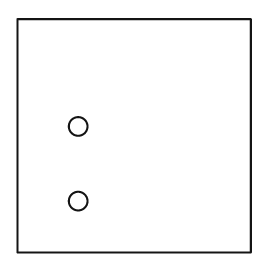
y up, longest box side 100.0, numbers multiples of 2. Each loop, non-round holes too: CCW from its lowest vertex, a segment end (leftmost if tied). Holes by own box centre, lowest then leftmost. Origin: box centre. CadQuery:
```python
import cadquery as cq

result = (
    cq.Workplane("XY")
    .moveTo(-50.0, -50.0)
    .lineTo(50.0, -50.0)
    .lineTo(50.0, 50.0)
    .lineTo(-50.0, 50.0)
    .close()
    .moveTo(-24.0, -28.0)
    .circle(4.0)
    .moveTo(-24.0, 4.0)
    .circle(4.0)
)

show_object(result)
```